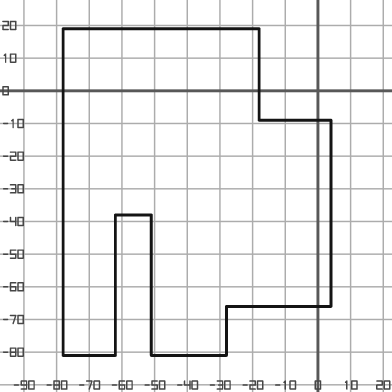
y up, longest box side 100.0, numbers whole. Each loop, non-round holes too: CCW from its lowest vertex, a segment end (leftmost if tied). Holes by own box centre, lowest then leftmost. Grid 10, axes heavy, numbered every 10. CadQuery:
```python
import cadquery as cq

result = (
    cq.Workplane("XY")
    .moveTo(-78.0, -81.0)
    .lineTo(-62.0, -81.0)
    .lineTo(-62.0, -38.0)
    .lineTo(-51.0, -38.0)
    .lineTo(-51.0, -81.0)
    .lineTo(-28.0, -81.0)
    .lineTo(-28.0, -66.0)
    .lineTo(4.0, -66.0)
    .lineTo(4.0, -9.0)
    .lineTo(-18.0, -9.0)
    .lineTo(-18.0, 19.0)
    .lineTo(-78.0, 19.0)
    .close()
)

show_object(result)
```